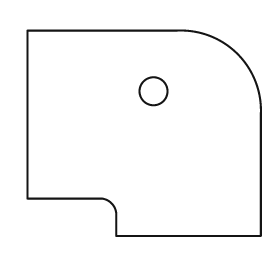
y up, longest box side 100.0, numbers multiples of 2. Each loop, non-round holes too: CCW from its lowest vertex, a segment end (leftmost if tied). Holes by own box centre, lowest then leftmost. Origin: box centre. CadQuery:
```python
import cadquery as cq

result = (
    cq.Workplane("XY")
    .moveTo(-12.0, -44.0)
    .lineTo(50.0, -44.0)
    .lineTo(50.0, 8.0)
    .threePointArc((40.0, 34.0), (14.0, 44.0))
    .lineTo(-50.0, 44.0)
    .lineTo(-50.0, -28.0)
    .lineTo(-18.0, -28.0)
    .threePointArc((-14.0, -30.0), (-12.0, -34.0))
    .close()
    .moveTo(4.0, 18.0)
    .circle(6.0)
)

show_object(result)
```